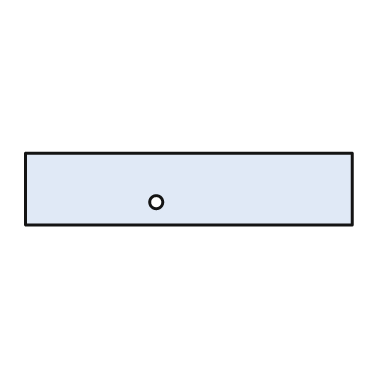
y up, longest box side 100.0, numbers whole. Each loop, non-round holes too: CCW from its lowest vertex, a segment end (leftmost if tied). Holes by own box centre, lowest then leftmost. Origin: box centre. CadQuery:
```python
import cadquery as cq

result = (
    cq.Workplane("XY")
    .moveTo(-50.0, -11.0)
    .lineTo(50.0, -11.0)
    .lineTo(50.0, 11.0)
    .lineTo(-50.0, 11.0)
    .close()
    .moveTo(-10.0, -4.0)
    .circle(2.0)
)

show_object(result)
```